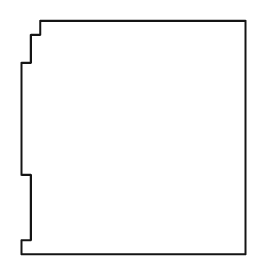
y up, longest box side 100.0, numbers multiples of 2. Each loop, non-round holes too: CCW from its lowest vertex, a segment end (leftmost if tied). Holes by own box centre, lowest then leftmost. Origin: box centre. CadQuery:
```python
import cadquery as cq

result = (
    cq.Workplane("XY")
    .moveTo(-48.0, -50.0)
    .lineTo(48.0, -50.0)
    .lineTo(48.0, 50.0)
    .lineTo(-40.0, 50.0)
    .lineTo(-40.0, 44.0)
    .lineTo(-44.0, 44.0)
    .lineTo(-44.0, 32.0)
    .lineTo(-48.0, 32.0)
    .lineTo(-48.0, -16.0)
    .lineTo(-44.0, -16.0)
    .lineTo(-44.0, -44.0)
    .lineTo(-48.0, -44.0)
    .close()
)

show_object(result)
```